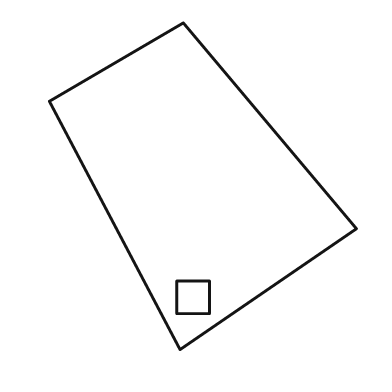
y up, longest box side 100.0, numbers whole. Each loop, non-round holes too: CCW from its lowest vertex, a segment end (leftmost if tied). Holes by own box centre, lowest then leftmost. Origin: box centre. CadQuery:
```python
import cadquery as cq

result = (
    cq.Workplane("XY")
    .moveTo(-7.0, -50.0)
    .lineTo(47.0, -13.0)
    .lineTo(-6.0, 50.0)
    .lineTo(-47.0, 26.0)
    .close()
    .moveTo(-8.0, -39.0)
    .lineTo(2.0, -39.0)
    .lineTo(2.0, -29.0)
    .lineTo(-8.0, -29.0)
    .close()
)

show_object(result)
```